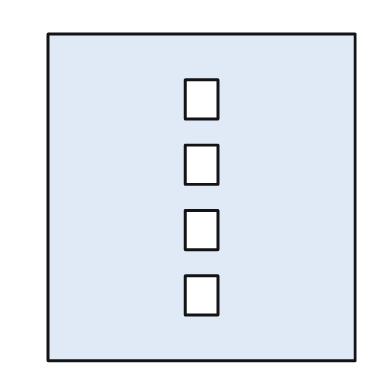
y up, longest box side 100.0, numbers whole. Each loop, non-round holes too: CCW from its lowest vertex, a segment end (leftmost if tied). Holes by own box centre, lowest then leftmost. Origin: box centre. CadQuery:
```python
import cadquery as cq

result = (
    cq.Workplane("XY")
    .moveTo(-47.0, -50.0)
    .lineTo(47.0, -50.0)
    .lineTo(47.0, 50.0)
    .lineTo(-47.0, 50.0)
    .close()
    .moveTo(-5.0, -36.0)
    .lineTo(5.0, -36.0)
    .lineTo(5.0, -24.0)
    .lineTo(-5.0, -24.0)
    .close()
    .moveTo(-5.0, -16.0)
    .lineTo(5.0, -16.0)
    .lineTo(5.0, -4.0)
    .lineTo(-5.0, -4.0)
    .close()
    .moveTo(-5.0, 4.0)
    .lineTo(5.0, 4.0)
    .lineTo(5.0, 16.0)
    .lineTo(-5.0, 16.0)
    .close()
    .moveTo(-5.0, 24.0)
    .lineTo(5.0, 24.0)
    .lineTo(5.0, 36.0)
    .lineTo(-5.0, 36.0)
    .close()
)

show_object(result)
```